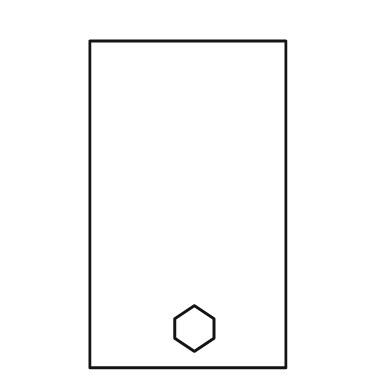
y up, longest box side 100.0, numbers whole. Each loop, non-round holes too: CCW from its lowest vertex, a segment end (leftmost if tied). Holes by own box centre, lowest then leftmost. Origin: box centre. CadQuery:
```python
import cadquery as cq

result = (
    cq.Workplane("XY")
    .moveTo(-30.0, -50.0)
    .lineTo(30.0, -50.0)
    .lineTo(30.0, 50.0)
    .lineTo(-30.0, 50.0)
    .close()
    .moveTo(2.0, -45.0)
    .lineTo(8.0, -41.0)
    .lineTo(8.0, -35.0)
    .lineTo(2.0, -31.0)
    .lineTo(-4.0, -35.0)
    .lineTo(-4.0, -41.0)
    .close()
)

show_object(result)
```